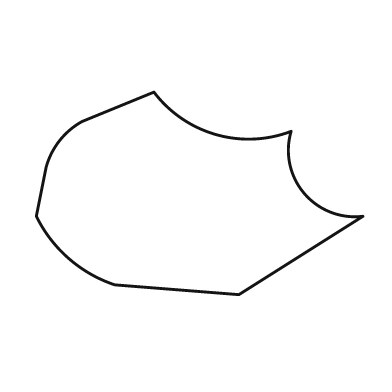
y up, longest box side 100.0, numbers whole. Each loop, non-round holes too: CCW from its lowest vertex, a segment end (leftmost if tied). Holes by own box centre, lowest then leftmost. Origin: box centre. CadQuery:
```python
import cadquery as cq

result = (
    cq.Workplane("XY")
    .moveTo(12.0, -31.0)
    .lineTo(50.0, -7.0)
    .threePointArc((32.0, 0.0), (28.0, 19.0))
    .threePointArc((5.0, 18.0), (-14.0, 31.0))
    .lineTo(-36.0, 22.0)
    .threePointArc((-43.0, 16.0), (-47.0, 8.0))
    .lineTo(-50.0, -7.0)
    .threePointArc((-40.0, -20.0), (-26.0, -28.0))
    .close()
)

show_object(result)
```